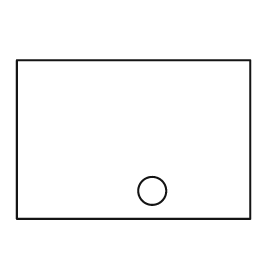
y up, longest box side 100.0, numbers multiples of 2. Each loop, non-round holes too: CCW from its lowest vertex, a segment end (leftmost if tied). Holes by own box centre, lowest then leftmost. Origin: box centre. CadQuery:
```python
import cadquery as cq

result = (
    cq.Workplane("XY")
    .moveTo(-50.0, -34.0)
    .lineTo(50.0, -34.0)
    .lineTo(50.0, 34.0)
    .lineTo(-50.0, 34.0)
    .close()
    .moveTo(8.0, -22.0)
    .circle(6.0)
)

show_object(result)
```